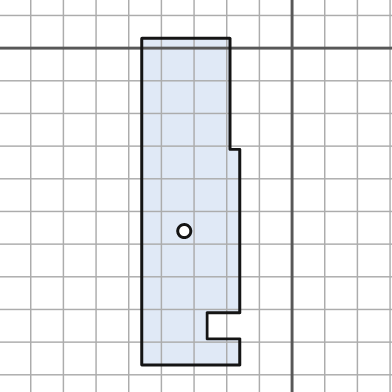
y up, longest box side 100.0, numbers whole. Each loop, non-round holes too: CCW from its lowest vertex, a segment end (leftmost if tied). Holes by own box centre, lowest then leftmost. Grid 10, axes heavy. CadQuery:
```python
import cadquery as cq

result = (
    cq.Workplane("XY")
    .moveTo(-46.0, -97.0)
    .lineTo(-16.0, -97.0)
    .lineTo(-16.0, -89.0)
    .lineTo(-26.0, -89.0)
    .lineTo(-26.0, -81.0)
    .lineTo(-16.0, -81.0)
    .lineTo(-16.0, -31.0)
    .lineTo(-19.0, -31.0)
    .lineTo(-19.0, 3.0)
    .lineTo(-46.0, 3.0)
    .close()
    .moveTo(-33.0, -56.0)
    .circle(2.0)
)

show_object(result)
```